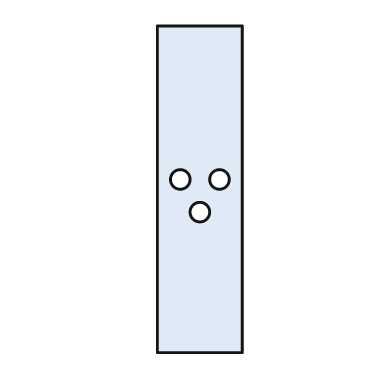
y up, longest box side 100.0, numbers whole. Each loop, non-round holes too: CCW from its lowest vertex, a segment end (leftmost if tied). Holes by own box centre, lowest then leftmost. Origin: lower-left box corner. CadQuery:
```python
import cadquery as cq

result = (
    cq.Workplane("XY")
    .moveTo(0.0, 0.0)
    .lineTo(26.0, 0.0)
    .lineTo(26.0, 100.0)
    .lineTo(0.0, 100.0)
    .close()
    .moveTo(13.0, 43.0)
    .circle(3.0)
    .moveTo(7.0, 53.0)
    .circle(3.0)
    .moveTo(19.0, 53.0)
    .circle(3.0)
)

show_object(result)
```